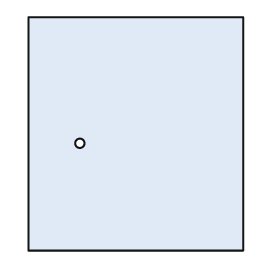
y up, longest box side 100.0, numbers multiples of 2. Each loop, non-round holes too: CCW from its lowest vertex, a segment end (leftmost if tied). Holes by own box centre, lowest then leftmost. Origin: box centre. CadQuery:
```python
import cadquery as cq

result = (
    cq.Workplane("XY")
    .moveTo(-46.0, -50.0)
    .lineTo(46.0, -50.0)
    .lineTo(46.0, 50.0)
    .lineTo(-46.0, 50.0)
    .close()
    .moveTo(-24.0, -4.0)
    .circle(2.0)
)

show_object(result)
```